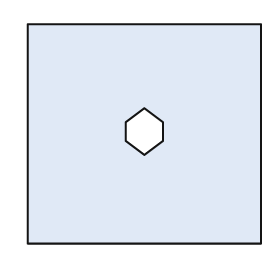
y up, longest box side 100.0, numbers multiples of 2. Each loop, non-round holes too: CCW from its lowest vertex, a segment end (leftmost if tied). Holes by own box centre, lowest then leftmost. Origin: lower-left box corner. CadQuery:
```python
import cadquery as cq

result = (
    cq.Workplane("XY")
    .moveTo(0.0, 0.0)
    .lineTo(100.0, 0.0)
    .lineTo(100.0, 94.0)
    .lineTo(0.0, 94.0)
    .close()
    .moveTo(50.0, 38.0)
    .lineTo(58.0, 44.0)
    .lineTo(58.0, 52.0)
    .lineTo(50.0, 58.0)
    .lineTo(42.0, 52.0)
    .lineTo(42.0, 44.0)
    .close()
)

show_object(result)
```